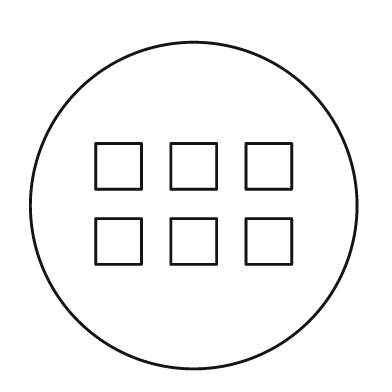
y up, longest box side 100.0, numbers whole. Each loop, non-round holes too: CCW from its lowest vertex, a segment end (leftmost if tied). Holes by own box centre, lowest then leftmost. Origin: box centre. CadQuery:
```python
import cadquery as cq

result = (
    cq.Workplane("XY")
    .moveTo(0.0, 0.0)
    .circle(50.0)
    .moveTo(-30.0, -18.0)
    .lineTo(-16.0, -18.0)
    .lineTo(-16.0, -4.0)
    .lineTo(-30.0, -4.0)
    .close()
    .moveTo(-7.0, -18.0)
    .lineTo(7.0, -18.0)
    .lineTo(7.0, -4.0)
    .lineTo(-7.0, -4.0)
    .close()
    .moveTo(16.0, -18.0)
    .lineTo(30.0, -18.0)
    .lineTo(30.0, -4.0)
    .lineTo(16.0, -4.0)
    .close()
    .moveTo(-30.0, 5.0)
    .lineTo(-16.0, 5.0)
    .lineTo(-16.0, 19.0)
    .lineTo(-30.0, 19.0)
    .close()
    .moveTo(-7.0, 5.0)
    .lineTo(7.0, 5.0)
    .lineTo(7.0, 19.0)
    .lineTo(-7.0, 19.0)
    .close()
    .moveTo(16.0, 5.0)
    .lineTo(30.0, 5.0)
    .lineTo(30.0, 19.0)
    .lineTo(16.0, 19.0)
    .close()
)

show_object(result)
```